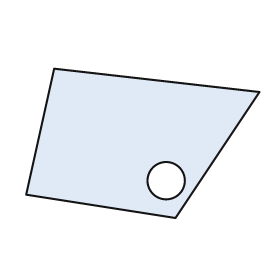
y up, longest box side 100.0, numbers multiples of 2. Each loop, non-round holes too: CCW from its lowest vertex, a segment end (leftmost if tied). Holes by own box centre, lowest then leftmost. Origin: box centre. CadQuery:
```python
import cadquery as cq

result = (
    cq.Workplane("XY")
    .moveTo(14.0, -32.0)
    .lineTo(50.0, 22.0)
    .lineTo(-38.0, 32.0)
    .lineTo(-50.0, -22.0)
    .close()
    .moveTo(10.0, -16.0)
    .circle(8.0)
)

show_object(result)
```